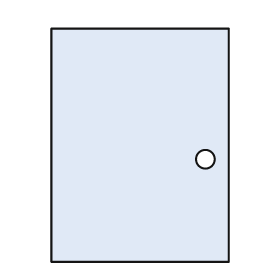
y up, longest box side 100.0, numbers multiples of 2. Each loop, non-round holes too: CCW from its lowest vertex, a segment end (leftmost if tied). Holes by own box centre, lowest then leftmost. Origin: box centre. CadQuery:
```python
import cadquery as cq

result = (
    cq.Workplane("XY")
    .moveTo(-38.0, -50.0)
    .lineTo(38.0, -50.0)
    .lineTo(38.0, 50.0)
    .lineTo(-38.0, 50.0)
    .close()
    .moveTo(28.0, -6.0)
    .circle(4.0)
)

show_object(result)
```